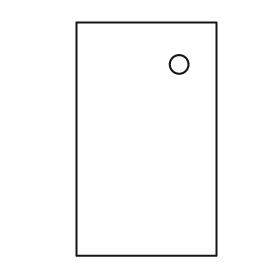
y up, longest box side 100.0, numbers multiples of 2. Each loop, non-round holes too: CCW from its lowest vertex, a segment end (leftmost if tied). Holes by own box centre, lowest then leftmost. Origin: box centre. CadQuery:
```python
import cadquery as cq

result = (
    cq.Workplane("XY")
    .moveTo(-30.0, -50.0)
    .lineTo(30.0, -50.0)
    .lineTo(30.0, 50.0)
    .lineTo(-30.0, 50.0)
    .close()
    .moveTo(14.0, 32.0)
    .circle(4.0)
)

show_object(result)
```